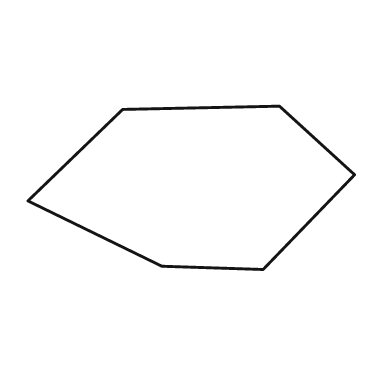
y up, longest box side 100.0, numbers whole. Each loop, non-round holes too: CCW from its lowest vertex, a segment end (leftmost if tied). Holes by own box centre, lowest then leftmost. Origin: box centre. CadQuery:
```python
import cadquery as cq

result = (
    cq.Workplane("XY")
    .moveTo(22.0, -25.0)
    .lineTo(50.0, 4.0)
    .lineTo(27.0, 25.0)
    .lineTo(-21.0, 24.0)
    .lineTo(-50.0, -4.0)
    .lineTo(-9.0, -24.0)
    .close()
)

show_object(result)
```